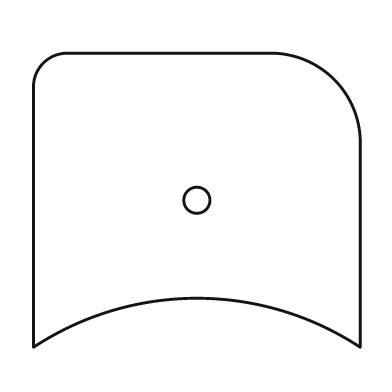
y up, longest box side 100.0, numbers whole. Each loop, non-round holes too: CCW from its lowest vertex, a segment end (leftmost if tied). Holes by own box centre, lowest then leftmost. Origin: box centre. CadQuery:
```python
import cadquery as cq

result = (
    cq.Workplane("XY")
    .moveTo(-50.0, -45.0)
    .threePointArc((0.0, -30.0), (50.0, -45.0))
    .lineTo(50.0, 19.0)
    .threePointArc((42.0, 37.0), (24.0, 45.0))
    .lineTo(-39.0, 45.0)
    .threePointArc((-47.0, 42.0), (-50.0, 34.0))
    .close()
    .moveTo(0.0, 0.0)
    .circle(4.0)
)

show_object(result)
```